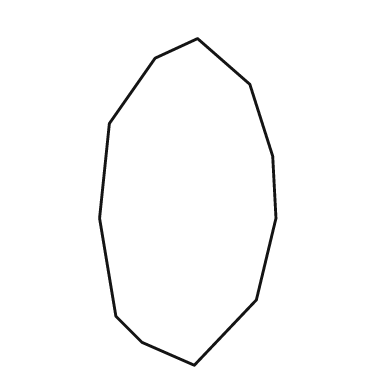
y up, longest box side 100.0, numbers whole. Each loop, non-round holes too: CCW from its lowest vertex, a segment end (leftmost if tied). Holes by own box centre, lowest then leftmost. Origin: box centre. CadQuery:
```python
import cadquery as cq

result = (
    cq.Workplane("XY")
    .moveTo(2.0, -50.0)
    .lineTo(21.0, -30.0)
    .lineTo(27.0, -5.0)
    .lineTo(26.0, 14.0)
    .lineTo(19.0, 36.0)
    .lineTo(3.0, 50.0)
    .lineTo(-10.0, 44.0)
    .lineTo(-24.0, 24.0)
    .lineTo(-27.0, -5.0)
    .lineTo(-22.0, -35.0)
    .lineTo(-14.0, -43.0)
    .close()
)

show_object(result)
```